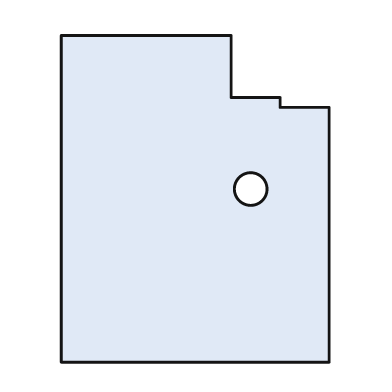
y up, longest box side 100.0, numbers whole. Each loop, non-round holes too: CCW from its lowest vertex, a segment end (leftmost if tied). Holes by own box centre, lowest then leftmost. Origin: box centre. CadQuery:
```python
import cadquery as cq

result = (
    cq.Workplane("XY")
    .moveTo(-41.0, -50.0)
    .lineTo(41.0, -50.0)
    .lineTo(41.0, 28.0)
    .lineTo(26.0, 28.0)
    .lineTo(26.0, 31.0)
    .lineTo(11.0, 31.0)
    .lineTo(11.0, 50.0)
    .lineTo(-41.0, 50.0)
    .close()
    .moveTo(17.0, 3.0)
    .circle(5.0)
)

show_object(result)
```